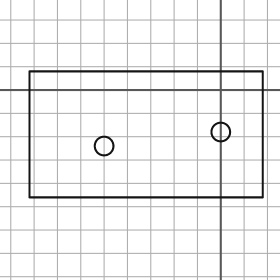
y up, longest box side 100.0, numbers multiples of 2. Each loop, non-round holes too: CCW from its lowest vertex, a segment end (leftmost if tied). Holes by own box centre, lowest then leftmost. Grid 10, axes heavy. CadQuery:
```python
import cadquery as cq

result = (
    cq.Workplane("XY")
    .moveTo(-82.0, -46.0)
    .lineTo(18.0, -46.0)
    .lineTo(18.0, 8.0)
    .lineTo(-82.0, 8.0)
    .close()
    .moveTo(-50.0, -24.0)
    .circle(4.0)
    .moveTo(0.0, -18.0)
    .circle(4.0)
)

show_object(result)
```